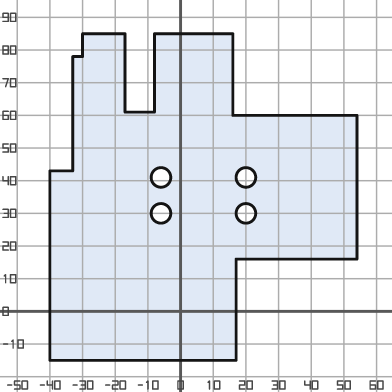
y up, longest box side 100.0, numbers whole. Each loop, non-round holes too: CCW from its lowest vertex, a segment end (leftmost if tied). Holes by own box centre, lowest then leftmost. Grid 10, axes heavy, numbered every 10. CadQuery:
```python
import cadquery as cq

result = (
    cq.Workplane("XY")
    .moveTo(-40.0, -15.0)
    .lineTo(17.0, -15.0)
    .lineTo(17.0, 16.0)
    .lineTo(54.0, 16.0)
    .lineTo(54.0, 60.0)
    .lineTo(16.0, 60.0)
    .lineTo(16.0, 85.0)
    .lineTo(-8.0, 85.0)
    .lineTo(-8.0, 61.0)
    .lineTo(-17.0, 61.0)
    .lineTo(-17.0, 85.0)
    .lineTo(-30.0, 85.0)
    .lineTo(-30.0, 78.0)
    .lineTo(-33.0, 78.0)
    .lineTo(-33.0, 43.0)
    .lineTo(-40.0, 43.0)
    .close()
    .moveTo(-6.0, 30.0)
    .circle(3.0)
    .moveTo(20.0, 30.0)
    .circle(3.0)
    .moveTo(-6.0, 41.0)
    .circle(3.0)
    .moveTo(20.0, 41.0)
    .circle(3.0)
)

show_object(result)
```